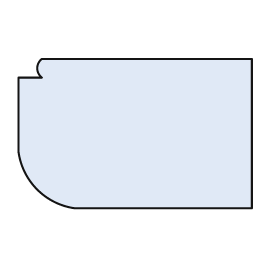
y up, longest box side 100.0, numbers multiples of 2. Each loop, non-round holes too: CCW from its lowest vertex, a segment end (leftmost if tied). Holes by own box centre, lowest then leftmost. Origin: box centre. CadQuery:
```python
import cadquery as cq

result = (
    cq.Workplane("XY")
    .moveTo(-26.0, -32.0)
    .lineTo(50.0, -32.0)
    .lineTo(50.0, 32.0)
    .lineTo(-40.0, 32.0)
    .threePointArc((-42.0, 28.0), (-40.0, 24.0))
    .lineTo(-50.0, 24.0)
    .lineTo(-50.0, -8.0)
    .threePointArc((-42.0, -24.0), (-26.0, -32.0))
    .close()
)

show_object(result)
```